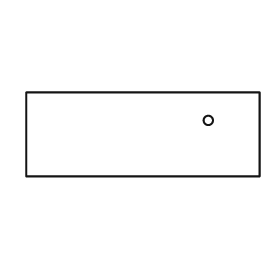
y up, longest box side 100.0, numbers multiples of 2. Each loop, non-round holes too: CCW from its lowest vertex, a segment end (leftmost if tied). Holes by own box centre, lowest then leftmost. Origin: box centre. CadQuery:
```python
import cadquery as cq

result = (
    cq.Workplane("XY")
    .moveTo(-50.0, -18.0)
    .lineTo(50.0, -18.0)
    .lineTo(50.0, 18.0)
    .lineTo(-50.0, 18.0)
    .close()
    .moveTo(28.0, 6.0)
    .circle(2.0)
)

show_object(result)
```